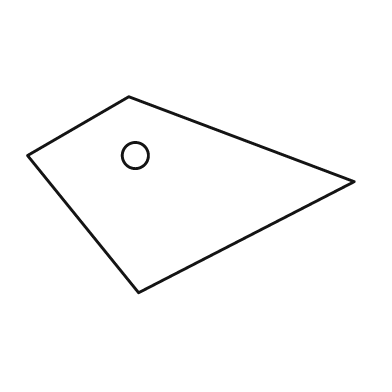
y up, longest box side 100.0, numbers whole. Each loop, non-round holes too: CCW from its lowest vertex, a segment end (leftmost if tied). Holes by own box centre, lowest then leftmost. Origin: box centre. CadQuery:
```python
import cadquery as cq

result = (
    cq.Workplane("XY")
    .moveTo(-16.0, -30.0)
    .lineTo(50.0, 4.0)
    .lineTo(-19.0, 30.0)
    .lineTo(-50.0, 12.0)
    .close()
    .moveTo(-17.0, 12.0)
    .circle(4.0)
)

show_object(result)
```